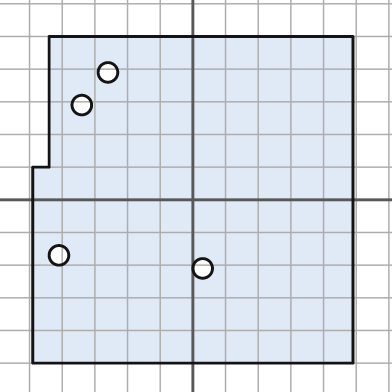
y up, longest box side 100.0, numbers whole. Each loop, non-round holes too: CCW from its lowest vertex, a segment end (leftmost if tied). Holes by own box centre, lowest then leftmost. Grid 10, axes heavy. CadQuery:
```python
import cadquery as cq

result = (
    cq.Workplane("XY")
    .moveTo(-49.0, -50.0)
    .lineTo(49.0, -50.0)
    .lineTo(49.0, 50.0)
    .lineTo(-44.0, 50.0)
    .lineTo(-44.0, 10.0)
    .lineTo(-49.0, 10.0)
    .close()
    .moveTo(3.0, -21.0)
    .circle(3.0)
    .moveTo(-41.0, -17.0)
    .circle(3.0)
    .moveTo(-34.0, 29.0)
    .circle(3.0)
    .moveTo(-26.0, 39.0)
    .circle(3.0)
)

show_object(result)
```